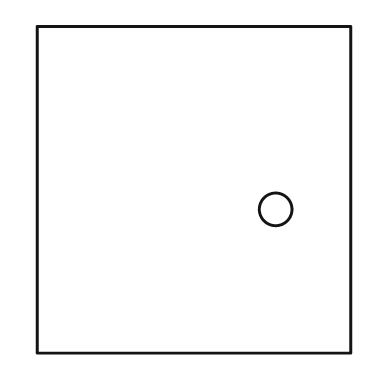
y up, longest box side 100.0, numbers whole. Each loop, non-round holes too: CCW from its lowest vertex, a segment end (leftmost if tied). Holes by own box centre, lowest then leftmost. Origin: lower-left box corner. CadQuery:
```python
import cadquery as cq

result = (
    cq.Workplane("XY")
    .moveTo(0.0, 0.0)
    .lineTo(96.0, 0.0)
    .lineTo(96.0, 100.0)
    .lineTo(0.0, 100.0)
    .close()
    .moveTo(73.0, 44.0)
    .circle(5.0)
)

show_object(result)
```